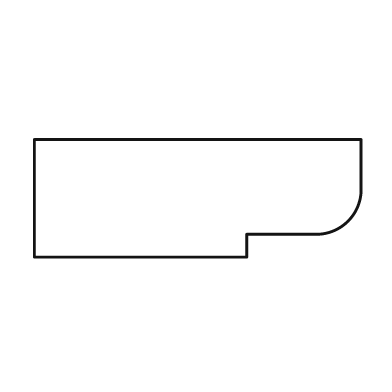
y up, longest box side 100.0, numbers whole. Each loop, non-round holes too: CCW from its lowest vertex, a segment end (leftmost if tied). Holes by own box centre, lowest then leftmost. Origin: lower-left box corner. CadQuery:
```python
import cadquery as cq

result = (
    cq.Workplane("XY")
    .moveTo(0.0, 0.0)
    .lineTo(65.0, 0.0)
    .lineTo(65.0, 7.0)
    .lineTo(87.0, 7.0)
    .threePointArc((96.0, 11.0), (100.0, 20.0))
    .lineTo(100.0, 36.0)
    .lineTo(0.0, 36.0)
    .close()
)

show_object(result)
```